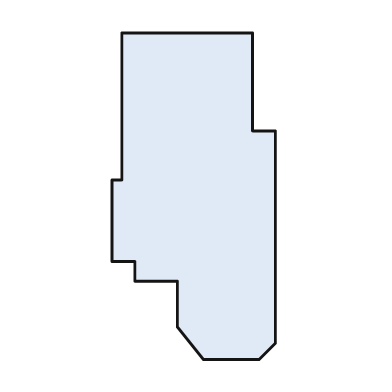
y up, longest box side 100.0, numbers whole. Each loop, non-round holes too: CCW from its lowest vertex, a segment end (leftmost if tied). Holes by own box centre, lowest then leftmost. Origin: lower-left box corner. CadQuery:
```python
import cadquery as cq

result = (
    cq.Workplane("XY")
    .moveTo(28.0, 0.0)
    .lineTo(45.0, 0.0)
    .lineTo(50.0, 5.0)
    .lineTo(50.0, 70.0)
    .lineTo(43.0, 70.0)
    .lineTo(43.0, 100.0)
    .lineTo(3.0, 100.0)
    .lineTo(3.0, 55.0)
    .lineTo(0.0, 55.0)
    .lineTo(0.0, 30.0)
    .lineTo(7.0, 30.0)
    .lineTo(7.0, 24.0)
    .lineTo(20.0, 24.0)
    .lineTo(20.0, 10.0)
    .close()
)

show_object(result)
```